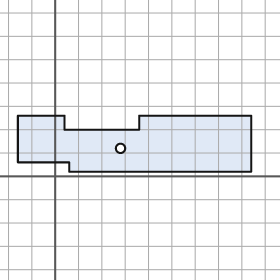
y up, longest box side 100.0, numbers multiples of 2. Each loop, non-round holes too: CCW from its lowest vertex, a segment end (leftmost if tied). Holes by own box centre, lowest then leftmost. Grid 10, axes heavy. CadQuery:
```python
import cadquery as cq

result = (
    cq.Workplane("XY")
    .moveTo(6.0, 2.0)
    .lineTo(84.0, 2.0)
    .lineTo(84.0, 26.0)
    .lineTo(36.0, 26.0)
    .lineTo(36.0, 20.0)
    .lineTo(4.0, 20.0)
    .lineTo(4.0, 26.0)
    .lineTo(-16.0, 26.0)
    .lineTo(-16.0, 6.0)
    .lineTo(6.0, 6.0)
    .close()
    .moveTo(28.0, 12.0)
    .circle(2.0)
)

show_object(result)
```